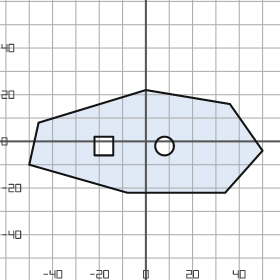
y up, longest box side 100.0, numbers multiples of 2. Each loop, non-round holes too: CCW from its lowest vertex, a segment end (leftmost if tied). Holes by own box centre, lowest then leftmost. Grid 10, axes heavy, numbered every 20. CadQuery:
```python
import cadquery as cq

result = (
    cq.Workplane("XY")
    .moveTo(-8.0, -22.0)
    .lineTo(34.0, -22.0)
    .lineTo(50.0, -4.0)
    .lineTo(36.0, 16.0)
    .lineTo(0.0, 22.0)
    .lineTo(-46.0, 8.0)
    .lineTo(-50.0, -10.0)
    .close()
    .moveTo(-22.0, -6.0)
    .lineTo(-14.0, -6.0)
    .lineTo(-14.0, 2.0)
    .lineTo(-22.0, 2.0)
    .close()
    .moveTo(8.0, -2.0)
    .circle(4.0)
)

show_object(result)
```